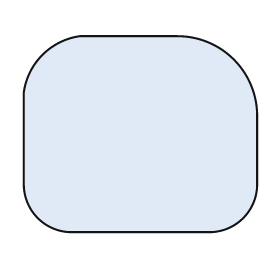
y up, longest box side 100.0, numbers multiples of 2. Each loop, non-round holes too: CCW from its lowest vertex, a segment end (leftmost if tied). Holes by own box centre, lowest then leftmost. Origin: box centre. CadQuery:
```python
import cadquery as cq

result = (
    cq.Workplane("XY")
    .moveTo(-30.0, -42.0)
    .lineTo(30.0, -42.0)
    .threePointArc((44.0, -36.0), (50.0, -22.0))
    .lineTo(50.0, 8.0)
    .threePointArc((40.0, 32.0), (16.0, 42.0))
    .lineTo(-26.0, 42.0)
    .threePointArc((-42.0, 34.0), (-50.0, 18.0))
    .lineTo(-50.0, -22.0)
    .threePointArc((-44.0, -36.0), (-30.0, -42.0))
    .close()
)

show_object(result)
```